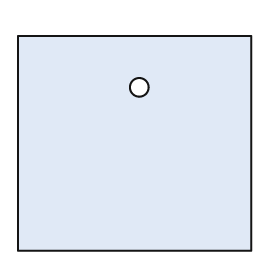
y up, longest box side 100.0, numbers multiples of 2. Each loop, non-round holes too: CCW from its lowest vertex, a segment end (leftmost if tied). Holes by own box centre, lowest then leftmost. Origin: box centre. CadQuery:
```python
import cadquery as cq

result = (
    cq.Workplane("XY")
    .moveTo(-50.0, -46.0)
    .lineTo(50.0, -46.0)
    .lineTo(50.0, 46.0)
    .lineTo(-50.0, 46.0)
    .close()
    .moveTo(2.0, 24.0)
    .circle(4.0)
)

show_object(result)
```